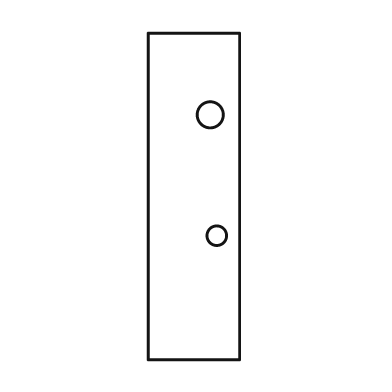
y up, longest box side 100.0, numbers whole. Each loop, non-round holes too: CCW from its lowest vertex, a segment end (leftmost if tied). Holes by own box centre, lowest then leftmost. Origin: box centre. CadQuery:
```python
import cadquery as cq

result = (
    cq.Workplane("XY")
    .moveTo(-14.0, -50.0)
    .lineTo(14.0, -50.0)
    .lineTo(14.0, 50.0)
    .lineTo(-14.0, 50.0)
    .close()
    .moveTo(7.0, -12.0)
    .circle(3.0)
    .moveTo(5.0, 25.0)
    .circle(4.0)
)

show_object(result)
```